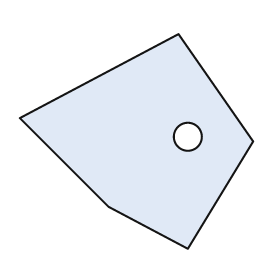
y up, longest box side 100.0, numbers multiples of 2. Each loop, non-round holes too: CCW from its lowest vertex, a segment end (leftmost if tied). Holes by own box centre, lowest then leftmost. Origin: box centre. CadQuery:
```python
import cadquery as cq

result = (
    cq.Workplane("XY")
    .moveTo(22.0, -46.0)
    .lineTo(50.0, 0.0)
    .lineTo(18.0, 46.0)
    .lineTo(-50.0, 10.0)
    .lineTo(-12.0, -28.0)
    .close()
    .moveTo(22.0, 2.0)
    .circle(6.0)
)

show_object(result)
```